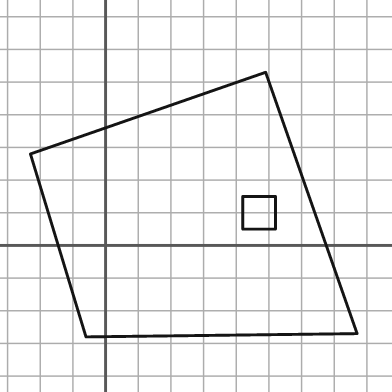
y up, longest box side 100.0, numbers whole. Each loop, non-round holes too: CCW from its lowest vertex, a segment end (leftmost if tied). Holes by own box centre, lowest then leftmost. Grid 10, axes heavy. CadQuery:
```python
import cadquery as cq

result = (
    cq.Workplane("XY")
    .moveTo(-6.0, -28.0)
    .lineTo(77.0, -27.0)
    .lineTo(49.0, 53.0)
    .lineTo(-23.0, 28.0)
    .close()
    .moveTo(42.0, 5.0)
    .lineTo(52.0, 5.0)
    .lineTo(52.0, 15.0)
    .lineTo(42.0, 15.0)
    .close()
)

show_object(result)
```